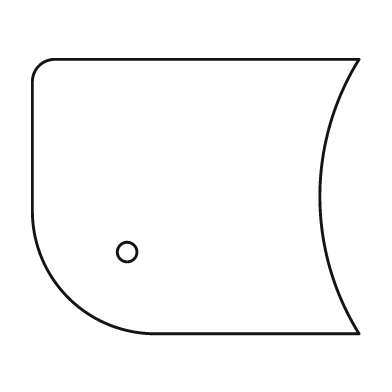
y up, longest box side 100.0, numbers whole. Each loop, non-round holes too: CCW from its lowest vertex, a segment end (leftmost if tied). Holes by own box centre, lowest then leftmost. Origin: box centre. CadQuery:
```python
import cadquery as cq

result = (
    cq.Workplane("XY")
    .moveTo(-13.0, -42.0)
    .lineTo(50.0, -42.0)
    .threePointArc((38.0, 0.0), (50.0, 42.0))
    .lineTo(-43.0, 42.0)
    .threePointArc((-48.0, 40.0), (-50.0, 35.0))
    .lineTo(-50.0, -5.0)
    .threePointArc((-39.0, -31.0), (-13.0, -42.0))
    .close()
    .moveTo(-21.0, -17.0)
    .circle(3.0)
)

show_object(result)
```